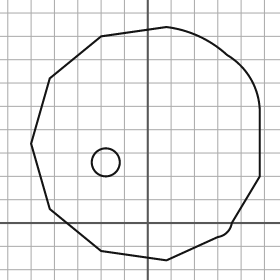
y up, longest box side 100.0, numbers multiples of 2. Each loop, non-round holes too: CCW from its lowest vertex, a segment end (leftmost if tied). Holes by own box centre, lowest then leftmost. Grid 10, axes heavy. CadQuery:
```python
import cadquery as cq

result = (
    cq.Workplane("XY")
    .moveTo(8.0, -16.0)
    .lineTo(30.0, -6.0)
    .threePointArc((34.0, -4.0), (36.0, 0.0))
    .lineTo(48.0, 20.0)
    .lineTo(48.0, 48.0)
    .threePointArc((44.0, 62.0), (34.0, 72.0))
    .threePointArc((22.0, 80.0), (8.0, 84.0))
    .lineTo(-20.0, 80.0)
    .lineTo(-42.0, 62.0)
    .lineTo(-50.0, 34.0)
    .lineTo(-42.0, 6.0)
    .lineTo(-20.0, -12.0)
    .close()
    .moveTo(-18.0, 26.0)
    .circle(6.0)
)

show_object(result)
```